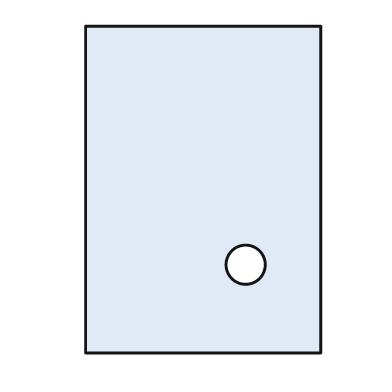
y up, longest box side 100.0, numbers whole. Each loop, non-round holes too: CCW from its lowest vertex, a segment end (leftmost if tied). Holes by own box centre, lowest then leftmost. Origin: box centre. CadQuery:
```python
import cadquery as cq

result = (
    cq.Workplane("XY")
    .moveTo(-36.0, -50.0)
    .lineTo(36.0, -50.0)
    .lineTo(36.0, 50.0)
    .lineTo(-36.0, 50.0)
    .close()
    .moveTo(13.0, -23.0)
    .circle(6.0)
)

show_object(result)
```